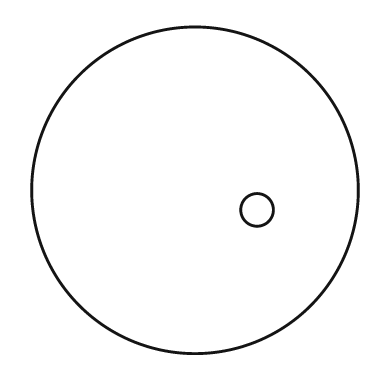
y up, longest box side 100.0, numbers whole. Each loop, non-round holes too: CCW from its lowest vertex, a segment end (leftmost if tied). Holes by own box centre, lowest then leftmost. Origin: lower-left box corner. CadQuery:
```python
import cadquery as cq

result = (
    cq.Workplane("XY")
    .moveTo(50.0, 50.0)
    .circle(50.0)
    .moveTo(69.0, 44.0)
    .circle(5.0)
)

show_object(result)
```